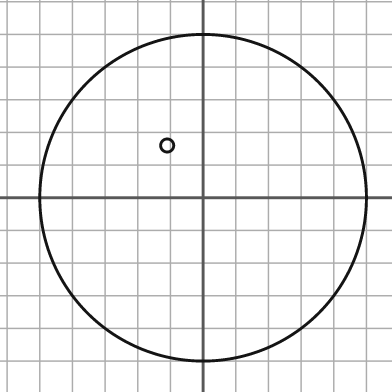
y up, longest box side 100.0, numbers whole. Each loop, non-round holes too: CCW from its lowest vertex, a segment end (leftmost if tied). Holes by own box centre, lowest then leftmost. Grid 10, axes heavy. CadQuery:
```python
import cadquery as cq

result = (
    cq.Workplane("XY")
    .moveTo(0.0, 0.0)
    .circle(50.0)
    .moveTo(-11.0, 16.0)
    .circle(2.0)
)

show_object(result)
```